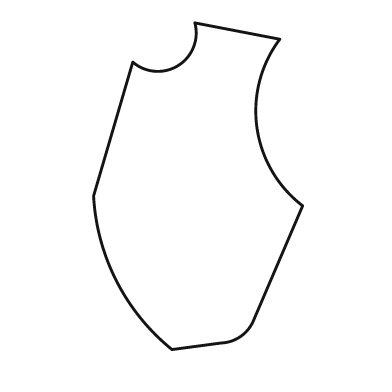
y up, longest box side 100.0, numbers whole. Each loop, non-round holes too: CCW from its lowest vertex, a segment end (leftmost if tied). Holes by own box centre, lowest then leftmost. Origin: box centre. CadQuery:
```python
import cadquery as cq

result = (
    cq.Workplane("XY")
    .moveTo(-8.0, -50.0)
    .lineTo(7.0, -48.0)
    .threePointArc((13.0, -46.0), (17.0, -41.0))
    .lineTo(32.0, -6.0)
    .threePointArc((18.0, 18.0), (25.0, 45.0))
    .lineTo(-1.0, 50.0)
    .threePointArc((-6.0, 37.0), (-20.0, 38.0))
    .lineTo(-32.0, -3.0)
    .threePointArc((-25.0, -29.0), (-8.0, -50.0))
    .close()
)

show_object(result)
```